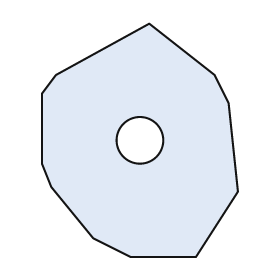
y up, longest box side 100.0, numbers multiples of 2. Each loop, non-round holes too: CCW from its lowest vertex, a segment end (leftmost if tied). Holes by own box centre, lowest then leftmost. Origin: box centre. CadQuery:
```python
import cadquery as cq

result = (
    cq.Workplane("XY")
    .moveTo(-4.0, -50.0)
    .lineTo(24.0, -50.0)
    .lineTo(42.0, -22.0)
    .lineTo(38.0, 16.0)
    .lineTo(32.0, 28.0)
    .lineTo(4.0, 50.0)
    .lineTo(-36.0, 28.0)
    .lineTo(-42.0, 20.0)
    .lineTo(-42.0, -10.0)
    .lineTo(-38.0, -20.0)
    .lineTo(-20.0, -42.0)
    .close()
    .moveTo(0.0, 0.0)
    .circle(10.0)
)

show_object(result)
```